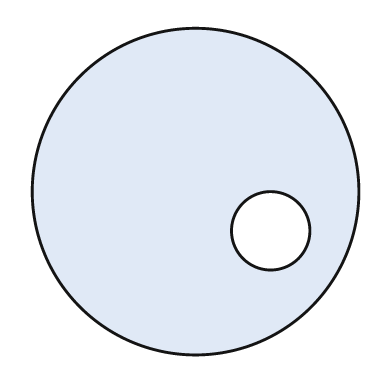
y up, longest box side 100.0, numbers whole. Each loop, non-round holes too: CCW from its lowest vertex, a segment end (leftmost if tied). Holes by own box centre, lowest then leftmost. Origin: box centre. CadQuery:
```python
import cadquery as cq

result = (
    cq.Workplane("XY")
    .moveTo(0.0, 0.0)
    .circle(50.0)
    .moveTo(23.0, -12.0)
    .circle(12.0)
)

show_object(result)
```